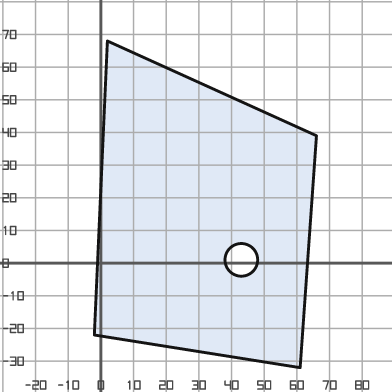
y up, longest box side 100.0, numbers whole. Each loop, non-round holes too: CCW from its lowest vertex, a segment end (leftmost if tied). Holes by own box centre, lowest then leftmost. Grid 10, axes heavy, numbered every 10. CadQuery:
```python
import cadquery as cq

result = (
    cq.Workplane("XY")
    .moveTo(61.0, -32.0)
    .lineTo(66.0, 39.0)
    .lineTo(2.0, 68.0)
    .lineTo(-2.0, -22.0)
    .close()
    .moveTo(43.0, 1.0)
    .circle(5.0)
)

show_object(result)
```